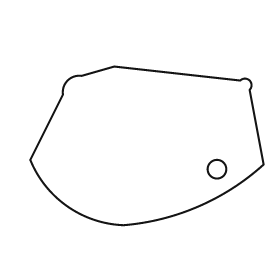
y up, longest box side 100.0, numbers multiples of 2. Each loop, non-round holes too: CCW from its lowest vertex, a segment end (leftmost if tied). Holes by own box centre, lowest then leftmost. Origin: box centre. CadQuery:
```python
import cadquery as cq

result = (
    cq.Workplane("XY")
    .moveTo(-10.0, -34.0)
    .threePointArc((22.0, -26.0), (50.0, -8.0))
    .lineTo(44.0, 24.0)
    .threePointArc((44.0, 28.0), (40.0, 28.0))
    .lineTo(-14.0, 34.0)
    .lineTo(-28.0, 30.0)
    .threePointArc((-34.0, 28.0), (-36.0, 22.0))
    .lineTo(-50.0, -6.0)
    .threePointArc((-34.0, -26.0), (-10.0, -34.0))
    .close()
    .moveTo(30.0, -10.0)
    .circle(4.0)
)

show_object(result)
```